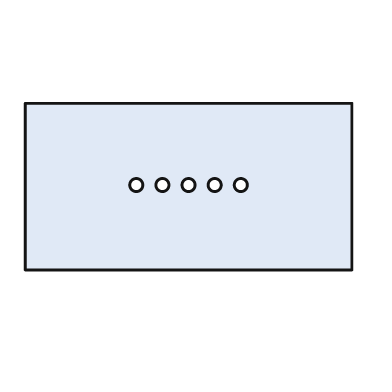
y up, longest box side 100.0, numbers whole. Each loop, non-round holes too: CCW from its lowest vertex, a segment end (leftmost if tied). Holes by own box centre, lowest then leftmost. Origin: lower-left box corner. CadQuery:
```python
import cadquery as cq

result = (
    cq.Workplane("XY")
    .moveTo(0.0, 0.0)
    .lineTo(100.0, 0.0)
    .lineTo(100.0, 51.0)
    .lineTo(0.0, 51.0)
    .close()
    .moveTo(34.0, 26.0)
    .circle(2.0)
    .moveTo(42.0, 26.0)
    .circle(2.0)
    .moveTo(50.0, 26.0)
    .circle(2.0)
    .moveTo(58.0, 26.0)
    .circle(2.0)
    .moveTo(66.0, 26.0)
    .circle(2.0)
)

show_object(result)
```